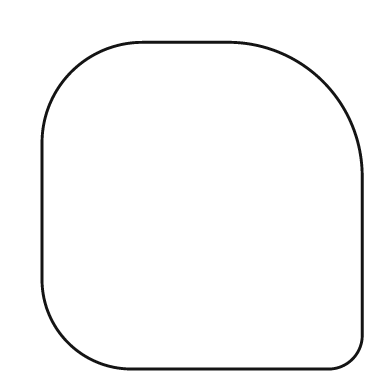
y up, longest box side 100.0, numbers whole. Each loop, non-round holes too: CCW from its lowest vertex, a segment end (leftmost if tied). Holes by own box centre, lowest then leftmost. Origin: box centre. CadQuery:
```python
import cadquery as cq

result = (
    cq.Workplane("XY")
    .moveTo(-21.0, -50.0)
    .lineTo(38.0, -50.0)
    .threePointArc((46.0, -47.0), (49.0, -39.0))
    .lineTo(49.0, 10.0)
    .threePointArc((37.0, 38.0), (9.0, 50.0))
    .lineTo(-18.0, 50.0)
    .threePointArc((-40.0, 41.0), (-49.0, 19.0))
    .lineTo(-49.0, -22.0)
    .threePointArc((-41.0, -42.0), (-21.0, -50.0))
    .close()
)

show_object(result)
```